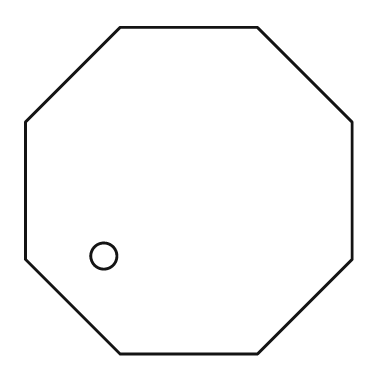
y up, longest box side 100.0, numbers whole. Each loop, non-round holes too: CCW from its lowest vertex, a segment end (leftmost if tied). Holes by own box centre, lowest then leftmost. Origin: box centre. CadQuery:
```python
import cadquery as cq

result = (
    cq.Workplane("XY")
    .moveTo(-21.0, -50.0)
    .lineTo(21.0, -50.0)
    .lineTo(50.0, -21.0)
    .lineTo(50.0, 21.0)
    .lineTo(21.0, 50.0)
    .lineTo(-21.0, 50.0)
    .lineTo(-50.0, 21.0)
    .lineTo(-50.0, -21.0)
    .close()
    .moveTo(-26.0, -20.0)
    .circle(4.0)
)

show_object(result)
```